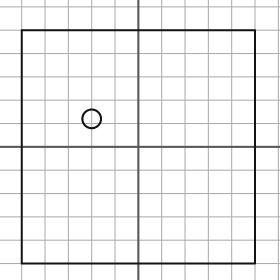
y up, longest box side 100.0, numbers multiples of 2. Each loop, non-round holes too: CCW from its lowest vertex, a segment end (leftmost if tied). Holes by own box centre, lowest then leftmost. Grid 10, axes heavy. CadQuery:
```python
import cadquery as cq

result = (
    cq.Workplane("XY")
    .moveTo(-50.0, -50.0)
    .lineTo(50.0, -50.0)
    .lineTo(50.0, 50.0)
    .lineTo(-50.0, 50.0)
    .close()
    .moveTo(-20.0, 12.0)
    .circle(4.0)
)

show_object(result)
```